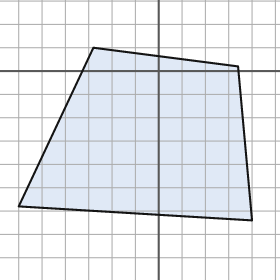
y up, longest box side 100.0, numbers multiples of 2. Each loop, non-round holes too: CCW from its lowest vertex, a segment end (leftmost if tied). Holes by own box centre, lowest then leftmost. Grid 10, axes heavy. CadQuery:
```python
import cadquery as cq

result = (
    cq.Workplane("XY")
    .moveTo(40.0, -64.0)
    .lineTo(34.0, 2.0)
    .lineTo(-28.0, 10.0)
    .lineTo(-60.0, -58.0)
    .close()
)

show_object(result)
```